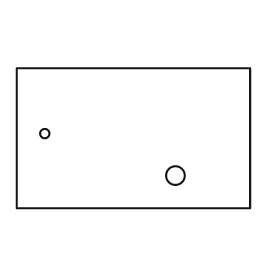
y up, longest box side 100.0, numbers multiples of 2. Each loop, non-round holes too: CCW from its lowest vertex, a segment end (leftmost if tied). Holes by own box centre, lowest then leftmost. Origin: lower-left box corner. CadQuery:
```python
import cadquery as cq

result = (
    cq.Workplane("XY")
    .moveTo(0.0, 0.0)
    .lineTo(100.0, 0.0)
    .lineTo(100.0, 60.0)
    .lineTo(0.0, 60.0)
    .close()
    .moveTo(68.0, 14.0)
    .circle(4.0)
    .moveTo(12.0, 32.0)
    .circle(2.0)
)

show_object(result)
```